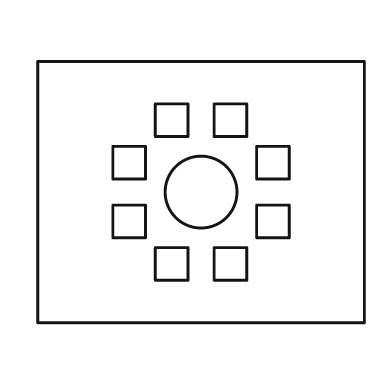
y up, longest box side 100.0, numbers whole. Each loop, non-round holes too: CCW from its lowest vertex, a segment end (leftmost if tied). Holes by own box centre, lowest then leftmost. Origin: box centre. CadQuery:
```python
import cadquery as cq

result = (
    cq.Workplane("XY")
    .moveTo(-50.0, -40.0)
    .lineTo(50.0, -40.0)
    .lineTo(50.0, 40.0)
    .lineTo(-50.0, 40.0)
    .close()
    .moveTo(-14.0, -27.0)
    .lineTo(-4.0, -27.0)
    .lineTo(-4.0, -17.0)
    .lineTo(-14.0, -17.0)
    .close()
    .moveTo(4.0, -27.0)
    .lineTo(14.0, -27.0)
    .lineTo(14.0, -17.0)
    .lineTo(4.0, -17.0)
    .close()
    .moveTo(-27.0, -14.0)
    .lineTo(-17.0, -14.0)
    .lineTo(-17.0, -4.0)
    .lineTo(-27.0, -4.0)
    .close()
    .moveTo(17.0, -14.0)
    .lineTo(27.0, -14.0)
    .lineTo(27.0, -4.0)
    .lineTo(17.0, -4.0)
    .close()
    .moveTo(0.0, 0.0)
    .circle(11.0)
    .moveTo(-27.0, 4.0)
    .lineTo(-17.0, 4.0)
    .lineTo(-17.0, 14.0)
    .lineTo(-27.0, 14.0)
    .close()
    .moveTo(17.0, 4.0)
    .lineTo(27.0, 4.0)
    .lineTo(27.0, 14.0)
    .lineTo(17.0, 14.0)
    .close()
    .moveTo(-14.0, 17.0)
    .lineTo(-4.0, 17.0)
    .lineTo(-4.0, 27.0)
    .lineTo(-14.0, 27.0)
    .close()
    .moveTo(4.0, 17.0)
    .lineTo(14.0, 17.0)
    .lineTo(14.0, 27.0)
    .lineTo(4.0, 27.0)
    .close()
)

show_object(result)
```